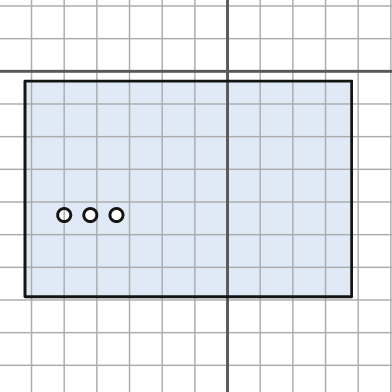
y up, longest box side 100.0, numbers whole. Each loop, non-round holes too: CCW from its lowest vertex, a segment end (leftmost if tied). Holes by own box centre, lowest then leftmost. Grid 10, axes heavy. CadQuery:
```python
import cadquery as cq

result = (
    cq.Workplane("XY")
    .moveTo(-62.0, -69.0)
    .lineTo(38.0, -69.0)
    .lineTo(38.0, -3.0)
    .lineTo(-62.0, -3.0)
    .close()
    .moveTo(-50.0, -44.0)
    .circle(2.0)
    .moveTo(-42.0, -44.0)
    .circle(2.0)
    .moveTo(-34.0, -44.0)
    .circle(2.0)
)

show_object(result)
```